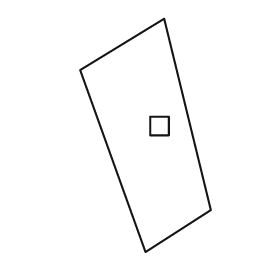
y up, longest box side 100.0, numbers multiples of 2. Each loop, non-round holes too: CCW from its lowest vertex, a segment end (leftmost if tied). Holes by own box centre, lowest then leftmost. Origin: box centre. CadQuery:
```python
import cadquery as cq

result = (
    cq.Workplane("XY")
    .moveTo(0.0, -50.0)
    .lineTo(28.0, -32.0)
    .lineTo(8.0, 50.0)
    .lineTo(-28.0, 28.0)
    .close()
    .moveTo(2.0, 0.0)
    .lineTo(10.0, 0.0)
    .lineTo(10.0, 8.0)
    .lineTo(2.0, 8.0)
    .close()
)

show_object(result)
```